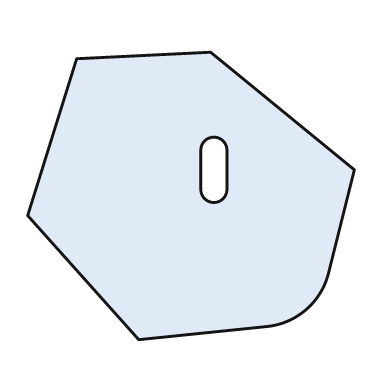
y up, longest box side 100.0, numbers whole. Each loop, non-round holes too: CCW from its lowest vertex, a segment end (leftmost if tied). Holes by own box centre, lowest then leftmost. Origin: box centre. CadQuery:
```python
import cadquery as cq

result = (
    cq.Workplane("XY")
    .moveTo(-16.0, -44.0)
    .lineTo(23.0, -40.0)
    .threePointArc((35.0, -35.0), (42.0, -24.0))
    .lineTo(50.0, 8.0)
    .lineTo(6.0, 44.0)
    .lineTo(-35.0, 42.0)
    .lineTo(-50.0, -6.0)
    .close()
    .moveTo(3.0, 2.0)
    .threePointArc((7.0, -2.0), (11.0, 2.0))
    .lineTo(11.0, 14.0)
    .threePointArc((7.0, 18.0), (3.0, 14.0))
    .close()
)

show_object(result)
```